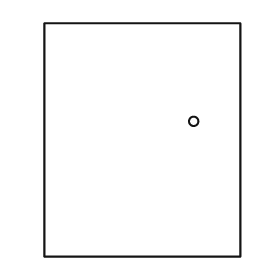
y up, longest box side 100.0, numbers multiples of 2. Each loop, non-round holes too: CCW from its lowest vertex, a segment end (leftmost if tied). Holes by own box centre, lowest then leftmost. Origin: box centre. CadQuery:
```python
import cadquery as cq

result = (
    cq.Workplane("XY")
    .moveTo(-42.0, -50.0)
    .lineTo(42.0, -50.0)
    .lineTo(42.0, 50.0)
    .lineTo(-42.0, 50.0)
    .close()
    .moveTo(22.0, 8.0)
    .circle(2.0)
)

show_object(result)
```